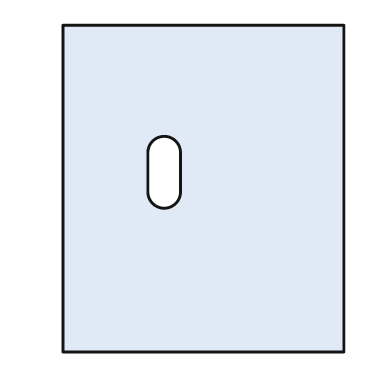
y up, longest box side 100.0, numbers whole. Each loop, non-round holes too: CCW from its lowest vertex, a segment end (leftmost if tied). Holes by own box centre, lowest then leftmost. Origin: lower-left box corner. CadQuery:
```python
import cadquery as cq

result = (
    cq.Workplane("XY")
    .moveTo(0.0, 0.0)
    .lineTo(86.0, 0.0)
    .lineTo(86.0, 100.0)
    .lineTo(0.0, 100.0)
    .close()
    .moveTo(26.0, 49.0)
    .threePointArc((31.0, 44.0), (36.0, 49.0))
    .lineTo(36.0, 61.0)
    .threePointArc((31.0, 66.0), (26.0, 61.0))
    .close()
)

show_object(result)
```